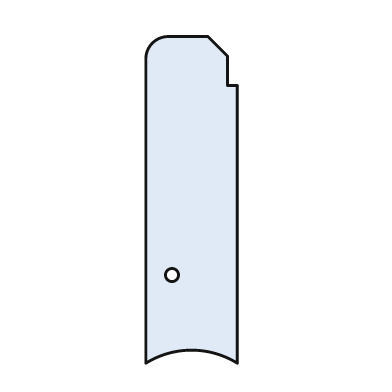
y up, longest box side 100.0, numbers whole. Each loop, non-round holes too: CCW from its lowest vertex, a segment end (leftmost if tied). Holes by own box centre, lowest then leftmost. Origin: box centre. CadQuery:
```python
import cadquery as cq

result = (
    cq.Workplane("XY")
    .moveTo(-14.0, -50.0)
    .threePointArc((0.0, -46.0), (14.0, -50.0))
    .lineTo(14.0, 35.0)
    .lineTo(11.0, 35.0)
    .lineTo(11.0, 44.0)
    .lineTo(5.0, 50.0)
    .lineTo(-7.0, 50.0)
    .threePointArc((-12.0, 48.0), (-14.0, 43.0))
    .close()
    .moveTo(-6.0, -23.0)
    .circle(2.0)
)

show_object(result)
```